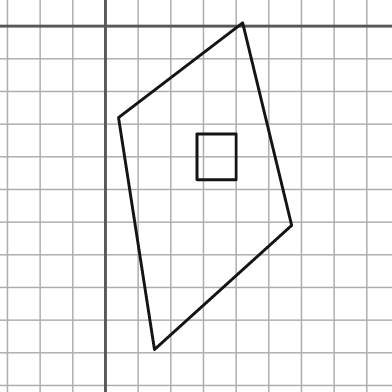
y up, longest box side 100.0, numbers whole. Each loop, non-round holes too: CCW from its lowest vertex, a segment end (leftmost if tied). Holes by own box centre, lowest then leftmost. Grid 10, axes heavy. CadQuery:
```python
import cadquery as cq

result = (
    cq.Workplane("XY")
    .moveTo(15.0, -99.0)
    .lineTo(57.0, -61.0)
    .lineTo(42.0, 1.0)
    .lineTo(4.0, -28.0)
    .close()
    .moveTo(28.0, -47.0)
    .lineTo(40.0, -47.0)
    .lineTo(40.0, -33.0)
    .lineTo(28.0, -33.0)
    .close()
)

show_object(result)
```